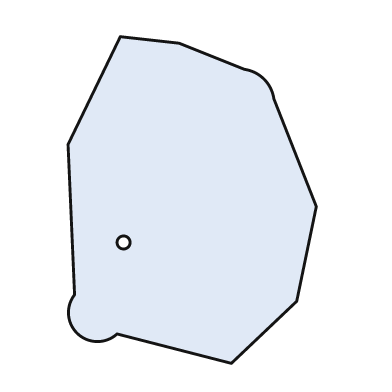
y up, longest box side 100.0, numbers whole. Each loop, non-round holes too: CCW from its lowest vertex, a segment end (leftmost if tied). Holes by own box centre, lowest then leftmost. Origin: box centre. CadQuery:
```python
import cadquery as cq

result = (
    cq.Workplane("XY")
    .moveTo(12.0, -50.0)
    .lineTo(32.0, -31.0)
    .lineTo(38.0, -2.0)
    .lineTo(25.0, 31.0)
    .threePointArc((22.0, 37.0), (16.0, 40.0))
    .lineTo(-4.0, 48.0)
    .lineTo(-22.0, 50.0)
    .lineTo(-38.0, 17.0)
    .lineTo(-36.0, -29.0)
    .threePointArc((-35.0, -41.0), (-23.0, -41.0))
    .close()
    .moveTo(-21.0, -13.0)
    .circle(2.0)
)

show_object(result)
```